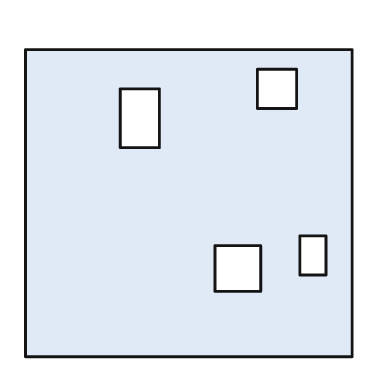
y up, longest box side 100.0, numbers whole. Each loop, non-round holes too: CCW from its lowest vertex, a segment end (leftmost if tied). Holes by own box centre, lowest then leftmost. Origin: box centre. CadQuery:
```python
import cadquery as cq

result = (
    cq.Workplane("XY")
    .moveTo(-50.0, -47.0)
    .lineTo(50.0, -47.0)
    .lineTo(50.0, 47.0)
    .lineTo(-50.0, 47.0)
    .close()
    .moveTo(8.0, -27.0)
    .lineTo(22.0, -27.0)
    .lineTo(22.0, -13.0)
    .lineTo(8.0, -13.0)
    .close()
    .moveTo(34.0, -22.0)
    .lineTo(42.0, -22.0)
    .lineTo(42.0, -10.0)
    .lineTo(34.0, -10.0)
    .close()
    .moveTo(-21.0, 17.0)
    .lineTo(-9.0, 17.0)
    .lineTo(-9.0, 35.0)
    .lineTo(-21.0, 35.0)
    .close()
    .moveTo(21.0, 29.0)
    .lineTo(33.0, 29.0)
    .lineTo(33.0, 41.0)
    .lineTo(21.0, 41.0)
    .close()
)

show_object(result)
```